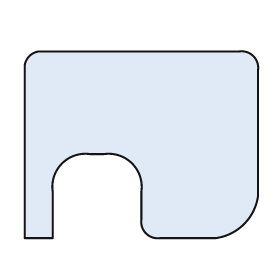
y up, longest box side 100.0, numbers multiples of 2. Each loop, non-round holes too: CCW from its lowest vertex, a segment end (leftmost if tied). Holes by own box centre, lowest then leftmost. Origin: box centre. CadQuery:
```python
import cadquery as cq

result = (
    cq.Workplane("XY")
    .moveTo(-50.0, -40.0)
    .lineTo(-38.0, -40.0)
    .lineTo(-38.0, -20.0)
    .threePointArc((-34.0, -8.0), (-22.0, -4.0))
    .lineTo(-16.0, -4.0)
    .threePointArc((-4.0, -8.0), (0.0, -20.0))
    .lineTo(0.0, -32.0)
    .threePointArc((2.0, -38.0), (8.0, -40.0))
    .lineTo(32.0, -40.0)
    .threePointArc((44.0, -34.0), (50.0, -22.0))
    .lineTo(50.0, 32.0)
    .threePointArc((48.0, 38.0), (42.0, 40.0))
    .lineTo(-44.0, 40.0)
    .threePointArc((-48.0, 38.0), (-50.0, 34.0))
    .close()
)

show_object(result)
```